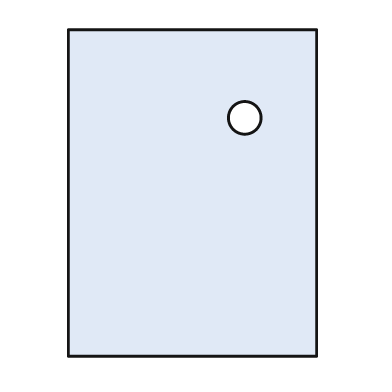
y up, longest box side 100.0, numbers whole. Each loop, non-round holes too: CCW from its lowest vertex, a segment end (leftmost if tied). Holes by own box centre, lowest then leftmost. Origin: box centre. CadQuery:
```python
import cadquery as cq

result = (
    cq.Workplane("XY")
    .moveTo(-38.0, -50.0)
    .lineTo(38.0, -50.0)
    .lineTo(38.0, 50.0)
    .lineTo(-38.0, 50.0)
    .close()
    .moveTo(16.0, 23.0)
    .circle(5.0)
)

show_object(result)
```